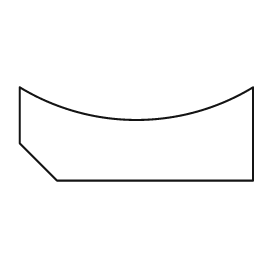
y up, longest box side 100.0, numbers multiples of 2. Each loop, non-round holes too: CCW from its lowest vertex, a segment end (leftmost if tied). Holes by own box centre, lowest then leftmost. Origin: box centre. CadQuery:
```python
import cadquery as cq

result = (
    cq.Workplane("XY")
    .moveTo(-34.0, -20.0)
    .lineTo(50.0, -20.0)
    .lineTo(50.0, 20.0)
    .threePointArc((0.0, 6.0), (-50.0, 20.0))
    .lineTo(-50.0, -4.0)
    .close()
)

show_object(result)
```